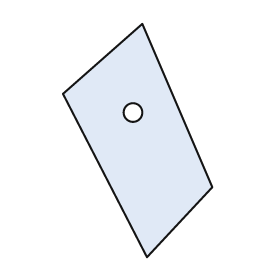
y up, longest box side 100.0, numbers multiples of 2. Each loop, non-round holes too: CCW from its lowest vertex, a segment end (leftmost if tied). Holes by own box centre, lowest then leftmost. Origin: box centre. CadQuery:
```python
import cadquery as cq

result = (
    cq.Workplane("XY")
    .moveTo(4.0, -50.0)
    .lineTo(32.0, -20.0)
    .lineTo(2.0, 50.0)
    .lineTo(-32.0, 20.0)
    .close()
    .moveTo(-2.0, 12.0)
    .circle(4.0)
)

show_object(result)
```